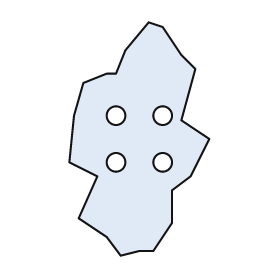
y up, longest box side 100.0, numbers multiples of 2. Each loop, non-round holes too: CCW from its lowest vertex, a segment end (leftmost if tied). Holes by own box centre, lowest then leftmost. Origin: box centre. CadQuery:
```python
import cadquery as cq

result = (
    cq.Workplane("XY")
    .moveTo(-8.0, -50.0)
    .lineTo(0.0, -48.0)
    .lineTo(6.0, -48.0)
    .lineTo(14.0, -36.0)
    .lineTo(14.0, -22.0)
    .lineTo(22.0, -16.0)
    .lineTo(30.0, 0.0)
    .lineTo(18.0, 8.0)
    .lineTo(24.0, 30.0)
    .lineTo(18.0, 36.0)
    .lineTo(10.0, 48.0)
    .lineTo(4.0, 50.0)
    .lineTo(-6.0, 38.0)
    .lineTo(-10.0, 28.0)
    .lineTo(-14.0, 28.0)
    .lineTo(-24.0, 24.0)
    .lineTo(-28.0, 10.0)
    .lineTo(-30.0, -10.0)
    .lineTo(-18.0, -16.0)
    .lineTo(-26.0, -34.0)
    .lineTo(-14.0, -42.0)
    .close()
    .moveTo(-10.0, -10.0)
    .circle(4.0)
    .moveTo(10.0, -10.0)
    .circle(4.0)
    .moveTo(-10.0, 10.0)
    .circle(4.0)
    .moveTo(10.0, 10.0)
    .circle(4.0)
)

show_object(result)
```